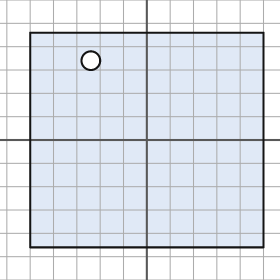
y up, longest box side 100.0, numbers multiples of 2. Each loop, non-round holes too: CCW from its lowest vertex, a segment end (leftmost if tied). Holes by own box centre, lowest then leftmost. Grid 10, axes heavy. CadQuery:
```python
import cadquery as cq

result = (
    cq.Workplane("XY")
    .moveTo(-50.0, -46.0)
    .lineTo(50.0, -46.0)
    .lineTo(50.0, 46.0)
    .lineTo(-50.0, 46.0)
    .close()
    .moveTo(-24.0, 34.0)
    .circle(4.0)
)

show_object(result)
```